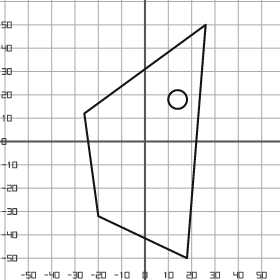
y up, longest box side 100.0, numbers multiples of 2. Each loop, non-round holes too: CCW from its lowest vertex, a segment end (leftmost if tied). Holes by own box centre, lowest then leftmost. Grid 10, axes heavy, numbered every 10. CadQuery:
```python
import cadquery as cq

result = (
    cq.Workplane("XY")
    .moveTo(18.0, -50.0)
    .lineTo(26.0, 50.0)
    .lineTo(-26.0, 12.0)
    .lineTo(-20.0, -32.0)
    .close()
    .moveTo(14.0, 18.0)
    .circle(4.0)
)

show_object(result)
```